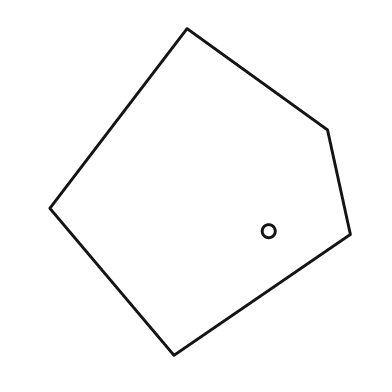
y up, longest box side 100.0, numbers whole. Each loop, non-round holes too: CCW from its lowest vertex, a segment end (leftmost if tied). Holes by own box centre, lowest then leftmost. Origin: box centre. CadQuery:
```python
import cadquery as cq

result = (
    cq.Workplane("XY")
    .moveTo(-8.0, -50.0)
    .lineTo(46.0, -13.0)
    .lineTo(39.0, 19.0)
    .lineTo(-4.0, 50.0)
    .lineTo(-46.0, -5.0)
    .close()
    .moveTo(21.0, -12.0)
    .circle(2.0)
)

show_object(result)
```